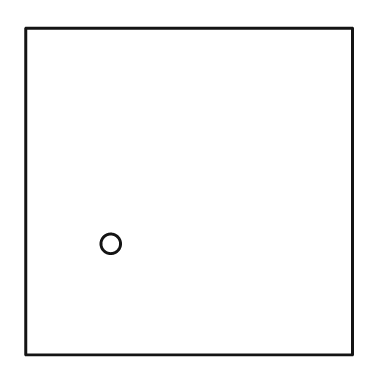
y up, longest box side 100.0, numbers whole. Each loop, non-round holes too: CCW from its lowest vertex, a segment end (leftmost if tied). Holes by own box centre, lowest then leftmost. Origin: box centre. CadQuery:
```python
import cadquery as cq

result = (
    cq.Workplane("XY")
    .moveTo(-50.0, -50.0)
    .lineTo(50.0, -50.0)
    .lineTo(50.0, 50.0)
    .lineTo(-50.0, 50.0)
    .close()
    .moveTo(-24.0, -16.0)
    .circle(3.0)
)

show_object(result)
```